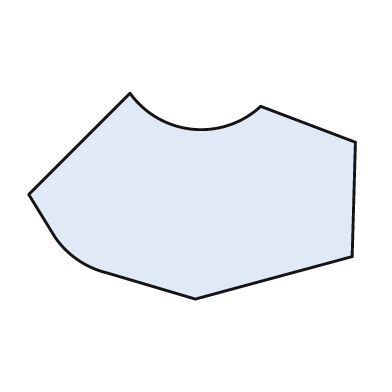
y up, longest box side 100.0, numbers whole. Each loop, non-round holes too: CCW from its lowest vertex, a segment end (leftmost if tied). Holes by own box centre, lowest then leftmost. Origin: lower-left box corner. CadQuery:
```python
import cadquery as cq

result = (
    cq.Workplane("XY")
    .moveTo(51.0, 0.0)
    .lineTo(99.0, 13.0)
    .lineTo(100.0, 48.0)
    .lineTo(71.0, 59.0)
    .threePointArc((50.0, 52.0), (31.0, 63.0))
    .lineTo(0.0, 32.0)
    .lineTo(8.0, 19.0)
    .threePointArc((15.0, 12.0), (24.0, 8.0))
    .close()
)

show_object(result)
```